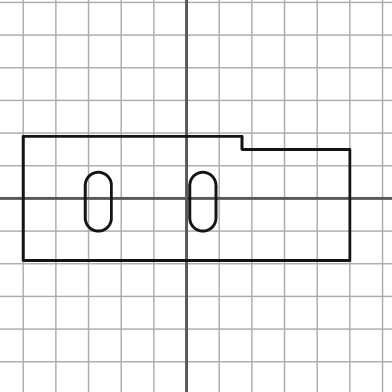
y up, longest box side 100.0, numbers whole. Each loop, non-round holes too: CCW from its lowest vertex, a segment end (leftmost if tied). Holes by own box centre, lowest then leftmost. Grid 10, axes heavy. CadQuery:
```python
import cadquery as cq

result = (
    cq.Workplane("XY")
    .moveTo(-50.0, -19.0)
    .lineTo(50.0, -19.0)
    .lineTo(50.0, 15.0)
    .lineTo(17.0, 15.0)
    .lineTo(17.0, 19.0)
    .lineTo(-50.0, 19.0)
    .close()
    .moveTo(-31.0, -6.0)
    .threePointArc((-27.0, -10.0), (-23.0, -6.0))
    .lineTo(-23.0, 4.0)
    .threePointArc((-27.0, 8.0), (-31.0, 4.0))
    .close()
    .moveTo(1.0, -6.0)
    .threePointArc((5.0, -10.0), (9.0, -6.0))
    .lineTo(9.0, 4.0)
    .threePointArc((5.0, 8.0), (1.0, 4.0))
    .close()
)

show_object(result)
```